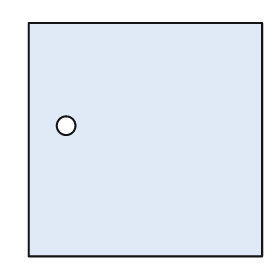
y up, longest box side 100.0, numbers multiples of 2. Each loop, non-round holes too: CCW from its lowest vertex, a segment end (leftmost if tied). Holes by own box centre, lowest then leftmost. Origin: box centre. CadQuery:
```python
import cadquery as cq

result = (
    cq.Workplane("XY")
    .moveTo(-50.0, -50.0)
    .lineTo(50.0, -50.0)
    .lineTo(50.0, 50.0)
    .lineTo(-50.0, 50.0)
    .close()
    .moveTo(-34.0, 6.0)
    .circle(4.0)
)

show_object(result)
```